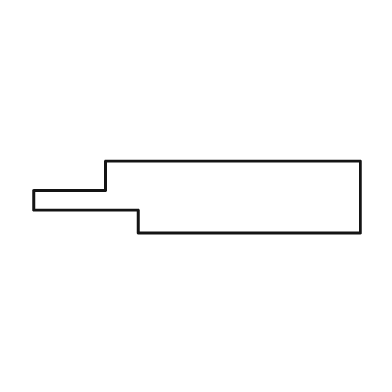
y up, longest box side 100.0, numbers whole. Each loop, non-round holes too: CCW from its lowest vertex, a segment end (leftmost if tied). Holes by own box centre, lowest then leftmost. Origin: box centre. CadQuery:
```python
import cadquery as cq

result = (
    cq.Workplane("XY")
    .moveTo(-18.0, -11.0)
    .lineTo(50.0, -11.0)
    .lineTo(50.0, 11.0)
    .lineTo(-28.0, 11.0)
    .lineTo(-28.0, 2.0)
    .lineTo(-50.0, 2.0)
    .lineTo(-50.0, -4.0)
    .lineTo(-18.0, -4.0)
    .close()
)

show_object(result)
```